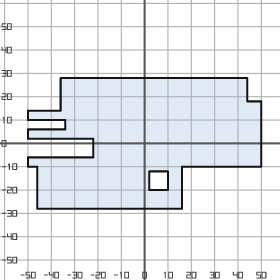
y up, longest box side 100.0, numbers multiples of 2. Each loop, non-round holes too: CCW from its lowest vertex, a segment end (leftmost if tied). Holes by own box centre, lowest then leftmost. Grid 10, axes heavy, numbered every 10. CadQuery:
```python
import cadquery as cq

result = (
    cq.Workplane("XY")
    .moveTo(-46.0, -28.0)
    .lineTo(16.0, -28.0)
    .lineTo(16.0, -10.0)
    .lineTo(50.0, -10.0)
    .lineTo(50.0, 18.0)
    .lineTo(44.0, 18.0)
    .lineTo(44.0, 28.0)
    .lineTo(-36.0, 28.0)
    .lineTo(-36.0, 14.0)
    .lineTo(-50.0, 14.0)
    .lineTo(-50.0, 10.0)
    .lineTo(-34.0, 10.0)
    .lineTo(-34.0, 6.0)
    .lineTo(-50.0, 6.0)
    .lineTo(-50.0, 2.0)
    .lineTo(-22.0, 2.0)
    .lineTo(-22.0, -6.0)
    .lineTo(-50.0, -6.0)
    .lineTo(-50.0, -10.0)
    .lineTo(-46.0, -10.0)
    .close()
    .moveTo(2.0, -20.0)
    .lineTo(10.0, -20.0)
    .lineTo(10.0, -12.0)
    .lineTo(2.0, -12.0)
    .close()
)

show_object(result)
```